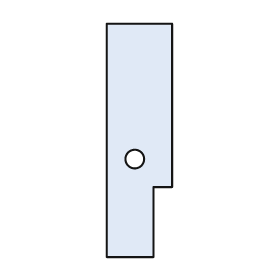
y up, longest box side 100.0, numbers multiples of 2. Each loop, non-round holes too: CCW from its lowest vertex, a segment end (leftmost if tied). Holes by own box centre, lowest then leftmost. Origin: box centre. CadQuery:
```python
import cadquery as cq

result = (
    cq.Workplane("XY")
    .moveTo(-14.0, -50.0)
    .lineTo(6.0, -50.0)
    .lineTo(6.0, -20.0)
    .lineTo(14.0, -20.0)
    .lineTo(14.0, 50.0)
    .lineTo(-14.0, 50.0)
    .close()
    .moveTo(-2.0, -8.0)
    .circle(4.0)
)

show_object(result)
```